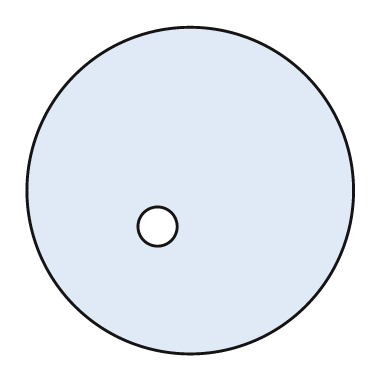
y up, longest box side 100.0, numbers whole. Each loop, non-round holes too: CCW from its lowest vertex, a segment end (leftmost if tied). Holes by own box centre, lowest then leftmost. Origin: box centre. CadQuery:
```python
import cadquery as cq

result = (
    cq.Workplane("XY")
    .moveTo(0.0, 0.0)
    .circle(50.0)
    .moveTo(-10.0, -11.0)
    .circle(6.0)
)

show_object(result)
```